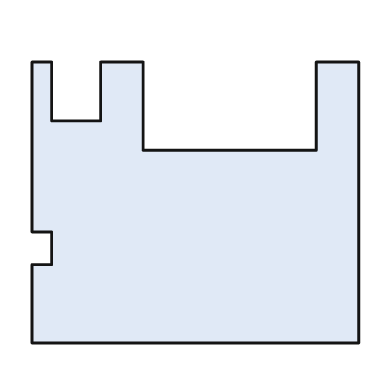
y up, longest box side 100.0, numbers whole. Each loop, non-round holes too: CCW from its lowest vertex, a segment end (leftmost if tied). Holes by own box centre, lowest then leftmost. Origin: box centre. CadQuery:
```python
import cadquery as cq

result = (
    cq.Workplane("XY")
    .moveTo(-50.0, -43.0)
    .lineTo(50.0, -43.0)
    .lineTo(50.0, 43.0)
    .lineTo(37.0, 43.0)
    .lineTo(37.0, 16.0)
    .lineTo(-16.0, 16.0)
    .lineTo(-16.0, 43.0)
    .lineTo(-29.0, 43.0)
    .lineTo(-29.0, 25.0)
    .lineTo(-44.0, 25.0)
    .lineTo(-44.0, 43.0)
    .lineTo(-50.0, 43.0)
    .lineTo(-50.0, -9.0)
    .lineTo(-44.0, -9.0)
    .lineTo(-44.0, -19.0)
    .lineTo(-50.0, -19.0)
    .close()
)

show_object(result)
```